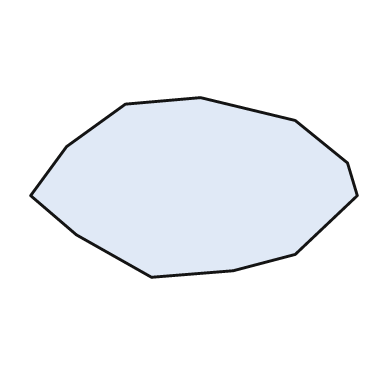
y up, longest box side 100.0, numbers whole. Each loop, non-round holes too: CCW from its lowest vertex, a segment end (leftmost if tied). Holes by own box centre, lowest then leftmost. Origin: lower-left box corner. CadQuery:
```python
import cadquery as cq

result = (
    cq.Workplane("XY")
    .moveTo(37.0, 0.0)
    .lineTo(62.0, 2.0)
    .lineTo(81.0, 7.0)
    .lineTo(100.0, 25.0)
    .lineTo(97.0, 35.0)
    .lineTo(81.0, 48.0)
    .lineTo(52.0, 55.0)
    .lineTo(29.0, 53.0)
    .lineTo(11.0, 40.0)
    .lineTo(0.0, 25.0)
    .lineTo(14.0, 13.0)
    .close()
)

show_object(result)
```